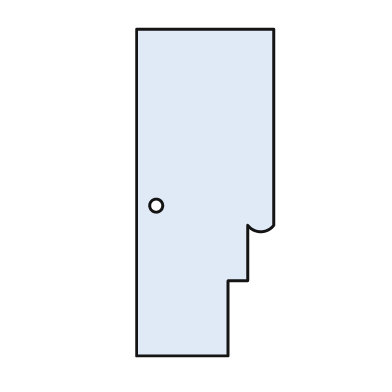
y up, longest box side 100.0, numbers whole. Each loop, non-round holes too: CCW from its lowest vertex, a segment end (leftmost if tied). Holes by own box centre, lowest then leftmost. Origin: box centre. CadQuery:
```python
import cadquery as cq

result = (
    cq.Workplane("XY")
    .moveTo(-21.0, -50.0)
    .lineTo(7.0, -50.0)
    .lineTo(7.0, -27.0)
    .lineTo(13.0, -27.0)
    .lineTo(13.0, -10.0)
    .threePointArc((17.0, -12.0), (21.0, -10.0))
    .lineTo(21.0, 50.0)
    .lineTo(-21.0, 50.0)
    .close()
    .moveTo(-15.0, -4.0)
    .circle(2.0)
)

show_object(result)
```